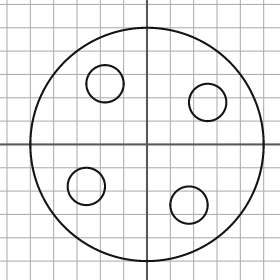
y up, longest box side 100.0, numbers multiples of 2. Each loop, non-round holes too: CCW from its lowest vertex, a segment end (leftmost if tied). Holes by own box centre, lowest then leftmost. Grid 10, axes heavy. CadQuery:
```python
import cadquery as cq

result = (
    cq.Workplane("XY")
    .moveTo(0.0, 0.0)
    .circle(50.0)
    .moveTo(18.0, -26.0)
    .circle(8.0)
    .moveTo(-26.0, -18.0)
    .circle(8.0)
    .moveTo(26.0, 18.0)
    .circle(8.0)
    .moveTo(-18.0, 26.0)
    .circle(8.0)
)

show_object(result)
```